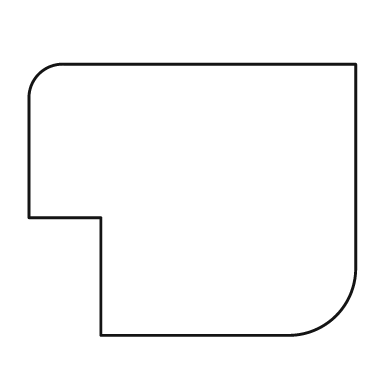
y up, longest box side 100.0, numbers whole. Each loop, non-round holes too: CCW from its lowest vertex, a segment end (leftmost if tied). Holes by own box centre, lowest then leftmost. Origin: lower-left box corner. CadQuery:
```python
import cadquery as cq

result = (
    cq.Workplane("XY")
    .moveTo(22.0, 0.0)
    .lineTo(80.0, 0.0)
    .threePointArc((94.0, 6.0), (100.0, 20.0))
    .lineTo(100.0, 83.0)
    .lineTo(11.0, 83.0)
    .threePointArc((3.0, 80.0), (0.0, 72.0))
    .lineTo(0.0, 36.0)
    .lineTo(22.0, 36.0)
    .close()
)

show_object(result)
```